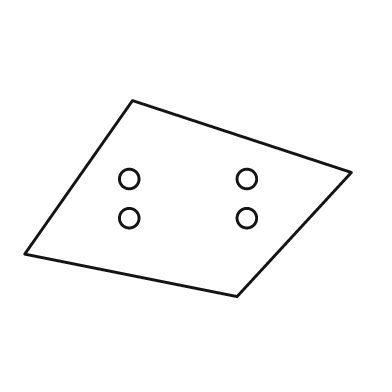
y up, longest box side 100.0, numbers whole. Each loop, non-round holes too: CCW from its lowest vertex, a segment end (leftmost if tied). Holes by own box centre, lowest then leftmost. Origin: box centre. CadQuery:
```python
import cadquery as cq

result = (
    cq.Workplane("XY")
    .moveTo(15.0, -30.0)
    .lineTo(50.0, 8.0)
    .lineTo(-17.0, 30.0)
    .lineTo(-50.0, -17.0)
    .close()
    .moveTo(-18.0, -6.0)
    .circle(3.0)
    .moveTo(18.0, -6.0)
    .circle(3.0)
    .moveTo(-18.0, 6.0)
    .circle(3.0)
    .moveTo(18.0, 6.0)
    .circle(3.0)
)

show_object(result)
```